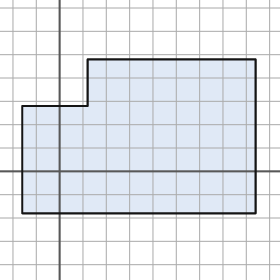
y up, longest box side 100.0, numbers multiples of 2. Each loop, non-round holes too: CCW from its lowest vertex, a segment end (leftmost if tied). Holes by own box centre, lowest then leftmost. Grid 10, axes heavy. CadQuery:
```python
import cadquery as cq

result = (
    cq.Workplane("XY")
    .moveTo(-16.0, -18.0)
    .lineTo(84.0, -18.0)
    .lineTo(84.0, 48.0)
    .lineTo(12.0, 48.0)
    .lineTo(12.0, 28.0)
    .lineTo(-16.0, 28.0)
    .close()
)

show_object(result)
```